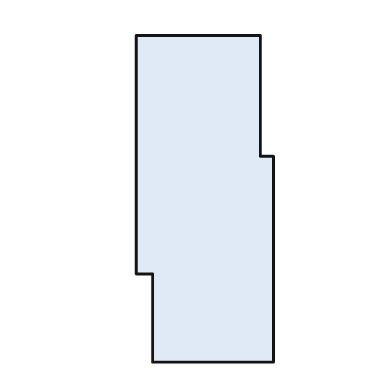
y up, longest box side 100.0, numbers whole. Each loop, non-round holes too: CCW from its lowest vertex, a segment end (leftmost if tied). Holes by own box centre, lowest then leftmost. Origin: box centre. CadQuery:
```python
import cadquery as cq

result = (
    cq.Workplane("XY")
    .moveTo(-16.0, -50.0)
    .lineTo(21.0, -50.0)
    .lineTo(21.0, 13.0)
    .lineTo(17.0, 13.0)
    .lineTo(17.0, 50.0)
    .lineTo(-21.0, 50.0)
    .lineTo(-21.0, -23.0)
    .lineTo(-16.0, -23.0)
    .close()
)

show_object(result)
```